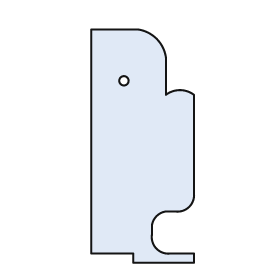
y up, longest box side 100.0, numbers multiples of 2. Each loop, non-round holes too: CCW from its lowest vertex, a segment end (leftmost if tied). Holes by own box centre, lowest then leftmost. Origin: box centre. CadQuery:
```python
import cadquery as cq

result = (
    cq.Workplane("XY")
    .moveTo(-4.0, -50.0)
    .lineTo(22.0, -50.0)
    .lineTo(22.0, -46.0)
    .lineTo(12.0, -46.0)
    .threePointArc((6.0, -44.0), (4.0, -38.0))
    .lineTo(4.0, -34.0)
    .threePointArc((6.0, -30.0), (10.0, -28.0))
    .lineTo(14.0, -28.0)
    .threePointArc((20.0, -26.0), (22.0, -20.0))
    .lineTo(22.0, 22.0)
    .threePointArc((16.0, 24.0), (10.0, 22.0))
    .lineTo(10.0, 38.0)
    .threePointArc((6.0, 46.0), (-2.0, 50.0))
    .lineTo(-22.0, 50.0)
    .lineTo(-22.0, -46.0)
    .lineTo(-4.0, -46.0)
    .close()
    .moveTo(-8.0, 28.0)
    .circle(2.0)
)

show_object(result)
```